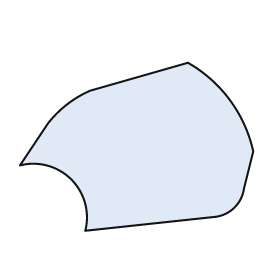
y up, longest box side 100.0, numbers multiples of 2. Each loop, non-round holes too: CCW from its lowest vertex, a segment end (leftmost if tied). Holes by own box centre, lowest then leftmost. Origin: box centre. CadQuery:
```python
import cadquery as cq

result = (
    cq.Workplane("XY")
    .moveTo(-22.0, -36.0)
    .lineTo(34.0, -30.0)
    .threePointArc((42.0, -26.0), (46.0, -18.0))
    .lineTo(50.0, -2.0)
    .threePointArc((40.0, 20.0), (22.0, 36.0))
    .lineTo(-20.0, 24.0)
    .threePointArc((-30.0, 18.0), (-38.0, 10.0))
    .lineTo(-50.0, -8.0)
    .threePointArc((-28.0, -14.0), (-22.0, -36.0))
    .close()
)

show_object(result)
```